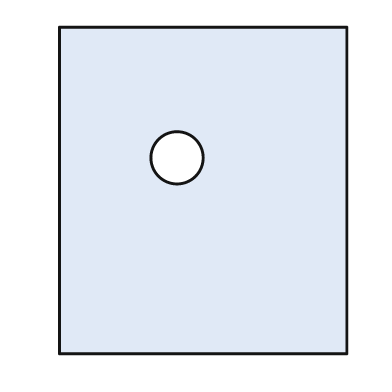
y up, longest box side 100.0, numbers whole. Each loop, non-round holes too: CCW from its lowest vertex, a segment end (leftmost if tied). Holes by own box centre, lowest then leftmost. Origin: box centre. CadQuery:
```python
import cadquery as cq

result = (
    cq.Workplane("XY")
    .moveTo(-44.0, -50.0)
    .lineTo(44.0, -50.0)
    .lineTo(44.0, 50.0)
    .lineTo(-44.0, 50.0)
    .close()
    .moveTo(-8.0, 10.0)
    .circle(8.0)
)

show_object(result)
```